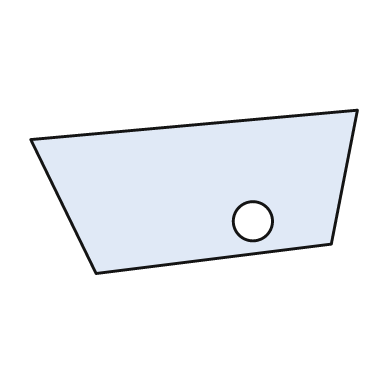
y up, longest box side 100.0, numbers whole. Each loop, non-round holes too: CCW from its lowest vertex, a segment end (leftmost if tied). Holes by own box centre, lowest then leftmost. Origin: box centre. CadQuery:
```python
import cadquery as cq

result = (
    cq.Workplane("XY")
    .moveTo(-30.0, -25.0)
    .lineTo(42.0, -16.0)
    .lineTo(50.0, 25.0)
    .lineTo(-50.0, 16.0)
    .close()
    .moveTo(18.0, -9.0)
    .circle(6.0)
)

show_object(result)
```